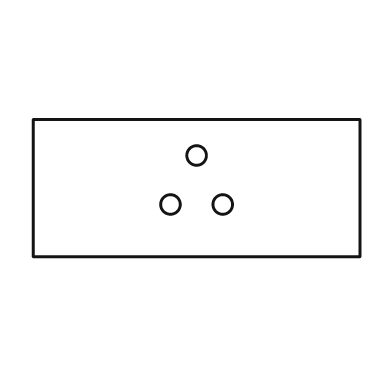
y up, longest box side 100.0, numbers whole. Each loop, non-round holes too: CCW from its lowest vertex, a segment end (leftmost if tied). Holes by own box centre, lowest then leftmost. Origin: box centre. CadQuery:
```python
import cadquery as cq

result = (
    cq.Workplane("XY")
    .moveTo(-50.0, -21.0)
    .lineTo(50.0, -21.0)
    .lineTo(50.0, 21.0)
    .lineTo(-50.0, 21.0)
    .close()
    .moveTo(-8.0, -5.0)
    .circle(3.0)
    .moveTo(8.0, -5.0)
    .circle(3.0)
    .moveTo(0.0, 10.0)
    .circle(3.0)
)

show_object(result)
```